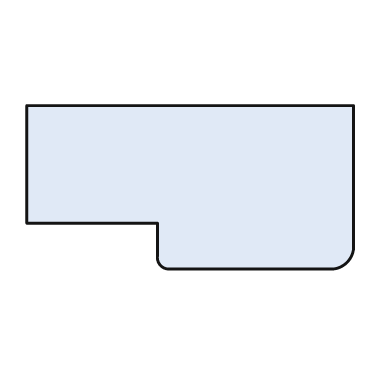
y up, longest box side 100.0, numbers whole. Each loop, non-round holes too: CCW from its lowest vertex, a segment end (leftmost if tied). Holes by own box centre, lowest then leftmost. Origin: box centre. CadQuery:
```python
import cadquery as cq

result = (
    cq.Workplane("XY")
    .moveTo(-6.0, -25.0)
    .lineTo(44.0, -25.0)
    .threePointArc((48.0, -23.0), (50.0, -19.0))
    .lineTo(50.0, 25.0)
    .lineTo(-50.0, 25.0)
    .lineTo(-50.0, -11.0)
    .lineTo(-10.0, -11.0)
    .lineTo(-10.0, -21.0)
    .threePointArc((-9.0, -24.0), (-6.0, -25.0))
    .close()
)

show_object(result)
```